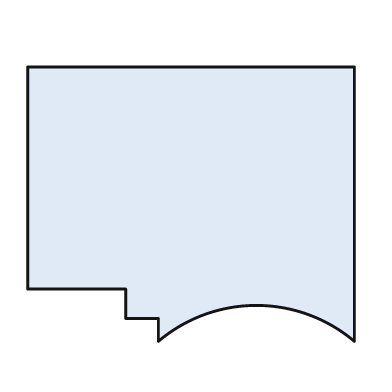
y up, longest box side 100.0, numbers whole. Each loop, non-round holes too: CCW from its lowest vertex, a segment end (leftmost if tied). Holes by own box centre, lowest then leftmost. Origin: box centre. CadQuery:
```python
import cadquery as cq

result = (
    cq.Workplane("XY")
    .moveTo(-10.0, -42.0)
    .threePointArc((20.0, -31.0), (50.0, -42.0))
    .lineTo(50.0, 42.0)
    .lineTo(-50.0, 42.0)
    .lineTo(-50.0, -26.0)
    .lineTo(-20.0, -26.0)
    .lineTo(-20.0, -35.0)
    .lineTo(-10.0, -35.0)
    .close()
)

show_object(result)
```